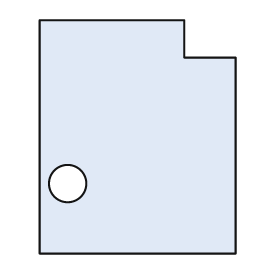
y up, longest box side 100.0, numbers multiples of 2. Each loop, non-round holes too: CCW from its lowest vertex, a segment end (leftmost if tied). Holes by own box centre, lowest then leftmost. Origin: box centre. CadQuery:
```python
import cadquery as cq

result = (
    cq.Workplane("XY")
    .moveTo(-42.0, -50.0)
    .lineTo(42.0, -50.0)
    .lineTo(42.0, 34.0)
    .lineTo(20.0, 34.0)
    .lineTo(20.0, 50.0)
    .lineTo(-42.0, 50.0)
    .close()
    .moveTo(-30.0, -20.0)
    .circle(8.0)
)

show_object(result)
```